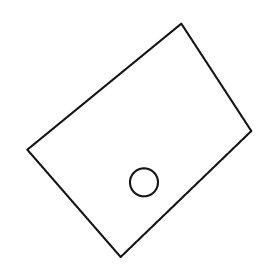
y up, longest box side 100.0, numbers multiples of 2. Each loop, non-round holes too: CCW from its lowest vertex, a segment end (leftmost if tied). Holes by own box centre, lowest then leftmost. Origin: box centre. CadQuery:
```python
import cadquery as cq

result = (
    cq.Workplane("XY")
    .moveTo(-8.0, -50.0)
    .lineTo(48.0, 4.0)
    .lineTo(18.0, 50.0)
    .lineTo(-48.0, -4.0)
    .close()
    .moveTo(2.0, -18.0)
    .circle(6.0)
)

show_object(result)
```